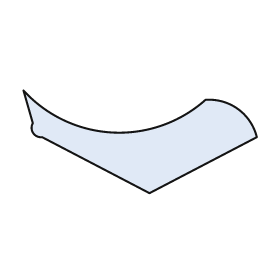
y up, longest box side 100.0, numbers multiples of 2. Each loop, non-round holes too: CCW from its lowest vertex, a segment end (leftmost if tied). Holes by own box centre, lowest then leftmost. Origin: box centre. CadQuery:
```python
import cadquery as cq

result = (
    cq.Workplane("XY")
    .moveTo(4.0, -22.0)
    .lineTo(50.0, 2.0)
    .threePointArc((42.0, 14.0), (28.0, 18.0))
    .threePointArc((-12.0, 4.0), (-50.0, 22.0))
    .lineTo(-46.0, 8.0)
    .threePointArc((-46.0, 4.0), (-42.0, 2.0))
    .close()
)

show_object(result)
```